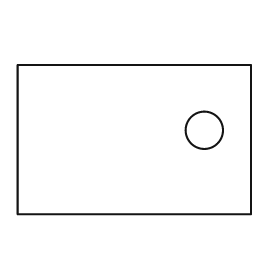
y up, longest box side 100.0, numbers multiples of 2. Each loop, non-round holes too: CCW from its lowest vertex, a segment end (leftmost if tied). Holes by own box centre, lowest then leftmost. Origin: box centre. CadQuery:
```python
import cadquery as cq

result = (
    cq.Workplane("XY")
    .moveTo(-50.0, -32.0)
    .lineTo(50.0, -32.0)
    .lineTo(50.0, 32.0)
    .lineTo(-50.0, 32.0)
    .close()
    .moveTo(30.0, 4.0)
    .circle(8.0)
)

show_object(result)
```